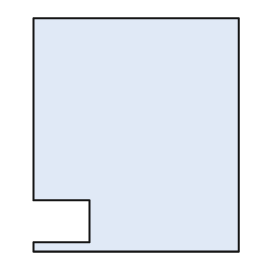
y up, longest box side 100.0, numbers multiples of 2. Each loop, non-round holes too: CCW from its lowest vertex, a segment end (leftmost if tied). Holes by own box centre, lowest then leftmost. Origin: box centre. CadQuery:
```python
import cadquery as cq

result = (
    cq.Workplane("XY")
    .moveTo(-44.0, -50.0)
    .lineTo(44.0, -50.0)
    .lineTo(44.0, 50.0)
    .lineTo(-44.0, 50.0)
    .lineTo(-44.0, -28.0)
    .lineTo(-20.0, -28.0)
    .lineTo(-20.0, -46.0)
    .lineTo(-44.0, -46.0)
    .close()
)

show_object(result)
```